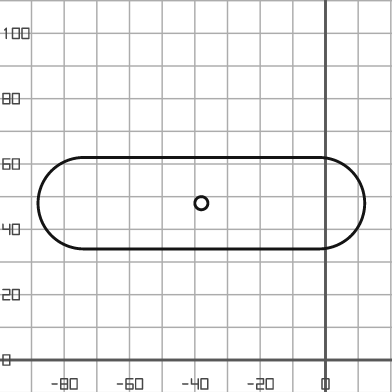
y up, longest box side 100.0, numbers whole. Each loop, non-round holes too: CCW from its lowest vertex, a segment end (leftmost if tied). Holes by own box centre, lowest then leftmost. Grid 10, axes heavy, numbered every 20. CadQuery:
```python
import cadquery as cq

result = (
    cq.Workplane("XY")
    .moveTo(-74.0, 34.0)
    .lineTo(-2.0, 34.0)
    .threePointArc((12.0, 48.0), (-2.0, 62.0))
    .lineTo(-74.0, 62.0)
    .threePointArc((-88.0, 48.0), (-74.0, 34.0))
    .close()
    .moveTo(-38.0, 48.0)
    .circle(2.0)
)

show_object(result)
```